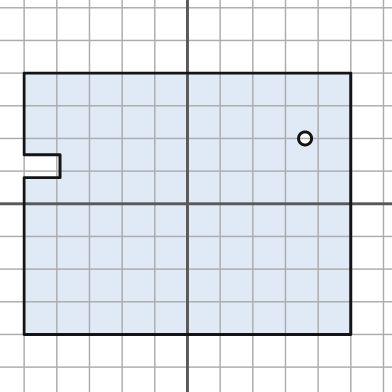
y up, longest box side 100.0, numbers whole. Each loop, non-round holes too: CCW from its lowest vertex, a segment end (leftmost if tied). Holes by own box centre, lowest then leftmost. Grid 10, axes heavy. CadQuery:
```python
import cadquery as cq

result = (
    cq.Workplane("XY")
    .moveTo(-50.0, -40.0)
    .lineTo(50.0, -40.0)
    .lineTo(50.0, 40.0)
    .lineTo(-50.0, 40.0)
    .lineTo(-50.0, 15.0)
    .lineTo(-39.0, 15.0)
    .lineTo(-39.0, 8.0)
    .lineTo(-50.0, 8.0)
    .close()
    .moveTo(36.0, 20.0)
    .circle(2.0)
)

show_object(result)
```